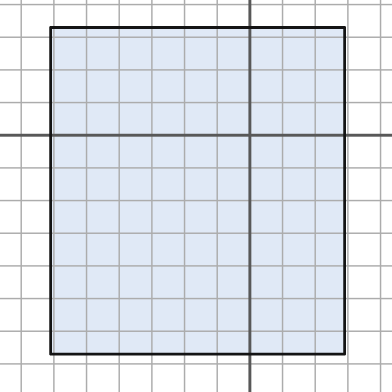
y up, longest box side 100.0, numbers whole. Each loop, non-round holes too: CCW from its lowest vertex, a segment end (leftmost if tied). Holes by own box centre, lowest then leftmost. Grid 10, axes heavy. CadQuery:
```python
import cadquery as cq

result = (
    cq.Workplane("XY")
    .moveTo(-61.0, -67.0)
    .lineTo(29.0, -67.0)
    .lineTo(29.0, 33.0)
    .lineTo(-61.0, 33.0)
    .close()
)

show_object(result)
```